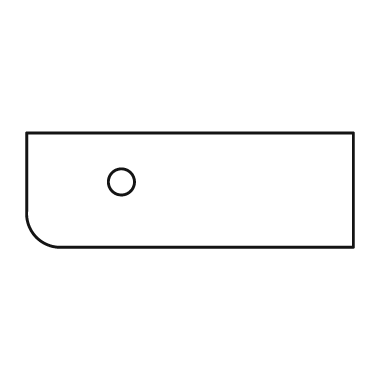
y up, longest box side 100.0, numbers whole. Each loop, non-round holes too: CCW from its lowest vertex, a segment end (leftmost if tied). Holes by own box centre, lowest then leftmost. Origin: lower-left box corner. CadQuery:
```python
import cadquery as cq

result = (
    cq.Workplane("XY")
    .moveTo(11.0, 0.0)
    .lineTo(100.0, 0.0)
    .lineTo(100.0, 35.0)
    .lineTo(0.0, 35.0)
    .lineTo(0.0, 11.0)
    .threePointArc((3.0, 3.0), (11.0, 0.0))
    .close()
    .moveTo(29.0, 20.0)
    .circle(4.0)
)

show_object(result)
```